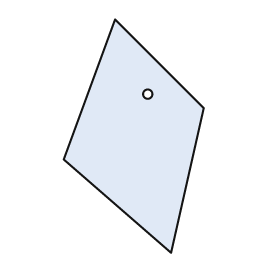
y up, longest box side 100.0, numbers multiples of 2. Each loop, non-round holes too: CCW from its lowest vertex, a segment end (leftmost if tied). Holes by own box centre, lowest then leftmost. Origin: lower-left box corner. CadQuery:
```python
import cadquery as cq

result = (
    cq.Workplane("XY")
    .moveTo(46.0, 0.0)
    .lineTo(60.0, 62.0)
    .lineTo(22.0, 100.0)
    .lineTo(0.0, 40.0)
    .close()
    .moveTo(36.0, 68.0)
    .circle(2.0)
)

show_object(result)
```